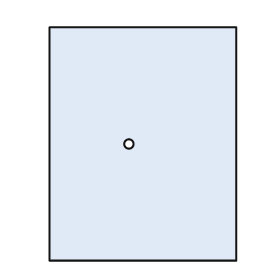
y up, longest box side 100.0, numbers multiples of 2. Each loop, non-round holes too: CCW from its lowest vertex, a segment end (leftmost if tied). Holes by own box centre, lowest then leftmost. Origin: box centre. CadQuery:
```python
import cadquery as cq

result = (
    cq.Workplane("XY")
    .moveTo(-40.0, -50.0)
    .lineTo(40.0, -50.0)
    .lineTo(40.0, 50.0)
    .lineTo(-40.0, 50.0)
    .close()
    .moveTo(-6.0, 0.0)
    .circle(2.0)
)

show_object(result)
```